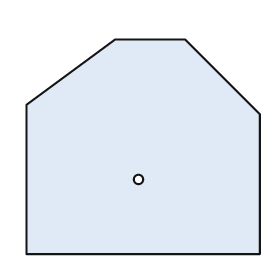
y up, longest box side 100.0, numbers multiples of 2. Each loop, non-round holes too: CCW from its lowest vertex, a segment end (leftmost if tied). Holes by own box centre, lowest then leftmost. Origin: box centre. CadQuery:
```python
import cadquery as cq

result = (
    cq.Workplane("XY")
    .moveTo(-50.0, -46.0)
    .lineTo(50.0, -46.0)
    .lineTo(50.0, 14.0)
    .lineTo(18.0, 46.0)
    .lineTo(-12.0, 46.0)
    .lineTo(-50.0, 18.0)
    .close()
    .moveTo(-2.0, -14.0)
    .circle(2.0)
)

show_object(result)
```